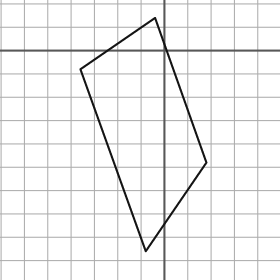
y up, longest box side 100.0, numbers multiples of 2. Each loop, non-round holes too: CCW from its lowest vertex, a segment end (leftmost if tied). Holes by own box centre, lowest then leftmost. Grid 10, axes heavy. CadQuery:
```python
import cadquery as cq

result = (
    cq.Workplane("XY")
    .moveTo(-8.0, -86.0)
    .lineTo(18.0, -48.0)
    .lineTo(-4.0, 14.0)
    .lineTo(-36.0, -8.0)
    .close()
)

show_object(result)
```